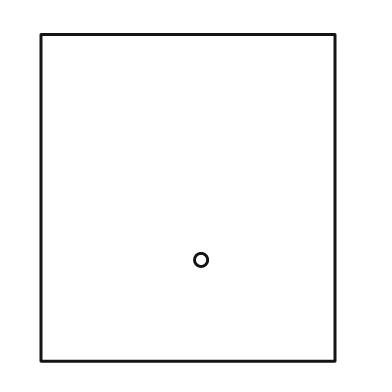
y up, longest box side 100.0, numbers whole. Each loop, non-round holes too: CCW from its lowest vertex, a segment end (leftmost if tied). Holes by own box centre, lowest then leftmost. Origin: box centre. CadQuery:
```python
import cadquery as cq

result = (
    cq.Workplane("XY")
    .moveTo(-45.0, -50.0)
    .lineTo(45.0, -50.0)
    .lineTo(45.0, 50.0)
    .lineTo(-45.0, 50.0)
    .close()
    .moveTo(4.0, -19.0)
    .circle(2.0)
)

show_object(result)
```